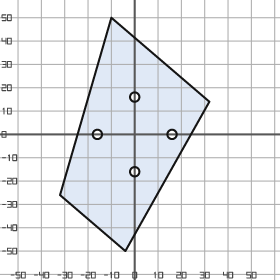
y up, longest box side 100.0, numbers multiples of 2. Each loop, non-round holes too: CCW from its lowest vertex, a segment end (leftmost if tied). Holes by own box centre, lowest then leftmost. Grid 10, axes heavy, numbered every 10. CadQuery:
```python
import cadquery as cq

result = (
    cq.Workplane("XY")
    .moveTo(-4.0, -50.0)
    .lineTo(32.0, 14.0)
    .lineTo(-10.0, 50.0)
    .lineTo(-32.0, -26.0)
    .close()
    .moveTo(0.0, -16.0)
    .circle(2.0)
    .moveTo(-16.0, 0.0)
    .circle(2.0)
    .moveTo(16.0, 0.0)
    .circle(2.0)
    .moveTo(0.0, 16.0)
    .circle(2.0)
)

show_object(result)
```